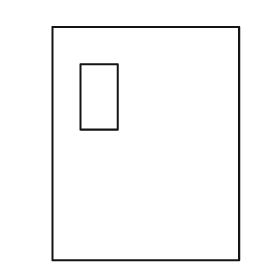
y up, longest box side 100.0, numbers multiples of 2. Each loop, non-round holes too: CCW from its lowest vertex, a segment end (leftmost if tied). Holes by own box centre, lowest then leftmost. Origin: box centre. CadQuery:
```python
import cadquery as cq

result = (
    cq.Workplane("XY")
    .moveTo(-40.0, -50.0)
    .lineTo(40.0, -50.0)
    .lineTo(40.0, 50.0)
    .lineTo(-40.0, 50.0)
    .close()
    .moveTo(-28.0, 6.0)
    .lineTo(-12.0, 6.0)
    .lineTo(-12.0, 34.0)
    .lineTo(-28.0, 34.0)
    .close()
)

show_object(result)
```